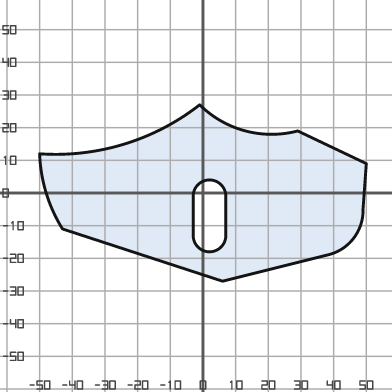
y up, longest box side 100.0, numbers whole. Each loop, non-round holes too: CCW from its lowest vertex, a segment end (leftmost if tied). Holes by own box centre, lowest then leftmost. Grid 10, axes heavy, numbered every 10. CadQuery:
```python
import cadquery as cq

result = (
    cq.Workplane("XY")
    .moveTo(6.0, -27.0)
    .lineTo(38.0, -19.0)
    .threePointArc((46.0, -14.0), (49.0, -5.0))
    .lineTo(50.0, 9.0)
    .lineTo(29.0, 19.0)
    .threePointArc((13.0, 19.0), (-1.0, 27.0))
    .threePointArc((-24.0, 15.0), (-50.0, 12.0))
    .threePointArc((-48.0, 0.0), (-43.0, -11.0))
    .close()
    .moveTo(-3.0, -13.0)
    .threePointArc((2.0, -18.0), (7.0, -13.0))
    .lineTo(7.0, -1.0)
    .threePointArc((2.0, 4.0), (-3.0, -1.0))
    .close()
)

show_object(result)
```